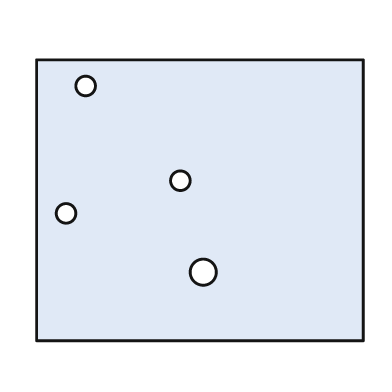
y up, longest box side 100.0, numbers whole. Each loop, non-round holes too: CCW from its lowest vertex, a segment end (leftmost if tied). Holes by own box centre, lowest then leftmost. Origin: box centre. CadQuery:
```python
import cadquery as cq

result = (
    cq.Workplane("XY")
    .moveTo(-50.0, -43.0)
    .lineTo(50.0, -43.0)
    .lineTo(50.0, 43.0)
    .lineTo(-50.0, 43.0)
    .close()
    .moveTo(1.0, -22.0)
    .circle(4.0)
    .moveTo(-41.0, -4.0)
    .circle(3.0)
    .moveTo(-6.0, 6.0)
    .circle(3.0)
    .moveTo(-35.0, 35.0)
    .circle(3.0)
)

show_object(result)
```